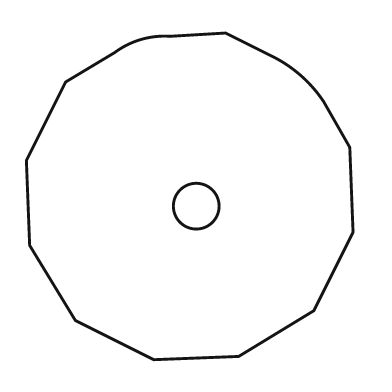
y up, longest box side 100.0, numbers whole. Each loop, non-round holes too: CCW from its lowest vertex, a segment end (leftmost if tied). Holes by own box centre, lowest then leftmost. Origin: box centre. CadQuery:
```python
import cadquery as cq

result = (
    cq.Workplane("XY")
    .moveTo(-11.0, -50.0)
    .lineTo(15.0, -49.0)
    .lineTo(38.0, -35.0)
    .lineTo(50.0, -11.0)
    .lineTo(49.0, 15.0)
    .lineTo(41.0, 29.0)
    .threePointArc((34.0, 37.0), (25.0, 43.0))
    .lineTo(11.0, 50.0)
    .lineTo(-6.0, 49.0)
    .threePointArc((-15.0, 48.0), (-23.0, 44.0))
    .lineTo(-38.0, 35.0)
    .lineTo(-50.0, 11.0)
    .lineTo(-49.0, -15.0)
    .lineTo(-35.0, -38.0)
    .close()
    .moveTo(2.0, -3.0)
    .circle(7.0)
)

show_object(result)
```